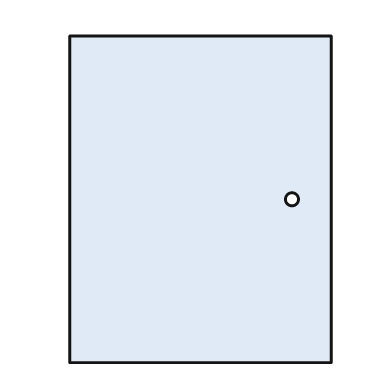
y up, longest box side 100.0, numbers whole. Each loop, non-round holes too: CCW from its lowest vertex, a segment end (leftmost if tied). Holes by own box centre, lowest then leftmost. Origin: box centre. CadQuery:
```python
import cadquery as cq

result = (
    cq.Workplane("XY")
    .moveTo(-40.0, -50.0)
    .lineTo(40.0, -50.0)
    .lineTo(40.0, 50.0)
    .lineTo(-40.0, 50.0)
    .close()
    .moveTo(28.0, 0.0)
    .circle(2.0)
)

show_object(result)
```